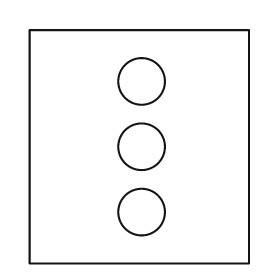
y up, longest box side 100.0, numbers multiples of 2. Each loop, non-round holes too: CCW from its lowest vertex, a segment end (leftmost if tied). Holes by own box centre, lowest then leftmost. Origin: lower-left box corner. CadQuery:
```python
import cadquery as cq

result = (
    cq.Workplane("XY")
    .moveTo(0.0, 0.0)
    .lineTo(94.0, 0.0)
    .lineTo(94.0, 100.0)
    .lineTo(0.0, 100.0)
    .close()
    .moveTo(48.0, 22.0)
    .circle(10.0)
    .moveTo(48.0, 50.0)
    .circle(10.0)
    .moveTo(48.0, 78.0)
    .circle(10.0)
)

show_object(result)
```